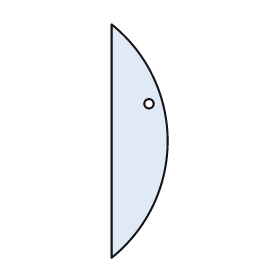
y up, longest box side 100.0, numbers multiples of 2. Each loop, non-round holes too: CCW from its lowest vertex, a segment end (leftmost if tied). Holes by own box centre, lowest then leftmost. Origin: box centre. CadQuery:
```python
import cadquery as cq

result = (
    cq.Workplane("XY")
    .moveTo(-12.0, -50.0)
    .threePointArc((12.0, 0.0), (-12.0, 50.0))
    .close()
    .moveTo(4.0, 16.0)
    .circle(2.0)
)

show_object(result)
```